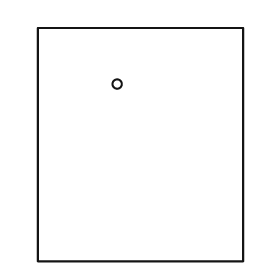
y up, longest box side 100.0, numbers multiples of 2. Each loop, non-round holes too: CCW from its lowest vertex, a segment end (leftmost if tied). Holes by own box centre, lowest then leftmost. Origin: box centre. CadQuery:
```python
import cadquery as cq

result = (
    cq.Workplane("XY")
    .moveTo(-44.0, -50.0)
    .lineTo(44.0, -50.0)
    .lineTo(44.0, 50.0)
    .lineTo(-44.0, 50.0)
    .close()
    .moveTo(-10.0, 26.0)
    .circle(2.0)
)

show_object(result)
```